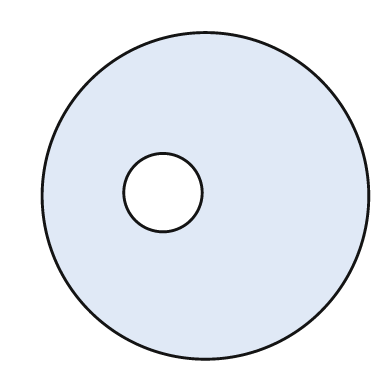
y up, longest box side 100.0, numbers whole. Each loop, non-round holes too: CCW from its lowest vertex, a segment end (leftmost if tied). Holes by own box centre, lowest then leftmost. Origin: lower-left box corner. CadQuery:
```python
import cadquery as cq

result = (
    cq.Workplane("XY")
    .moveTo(50.0, 50.0)
    .circle(50.0)
    .moveTo(37.0, 51.0)
    .circle(12.0)
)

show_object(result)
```